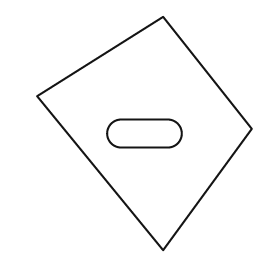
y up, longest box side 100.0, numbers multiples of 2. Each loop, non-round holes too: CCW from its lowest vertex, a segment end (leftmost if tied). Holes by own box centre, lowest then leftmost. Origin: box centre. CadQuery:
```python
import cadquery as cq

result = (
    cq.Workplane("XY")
    .moveTo(8.0, -50.0)
    .lineTo(46.0, 2.0)
    .lineTo(8.0, 50.0)
    .lineTo(-46.0, 16.0)
    .close()
    .moveTo(-10.0, -6.0)
    .lineTo(10.0, -6.0)
    .threePointArc((16.0, 0.0), (10.0, 6.0))
    .lineTo(-10.0, 6.0)
    .threePointArc((-16.0, 0.0), (-10.0, -6.0))
    .close()
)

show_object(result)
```